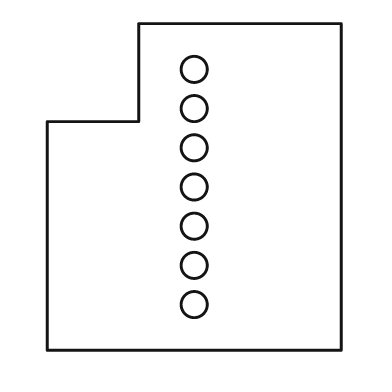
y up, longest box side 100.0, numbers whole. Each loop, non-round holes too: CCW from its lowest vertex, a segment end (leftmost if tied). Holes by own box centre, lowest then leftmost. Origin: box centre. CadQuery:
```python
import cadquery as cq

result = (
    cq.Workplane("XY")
    .moveTo(-45.0, -50.0)
    .lineTo(45.0, -50.0)
    .lineTo(45.0, 50.0)
    .lineTo(-17.0, 50.0)
    .lineTo(-17.0, 20.0)
    .lineTo(-45.0, 20.0)
    .close()
    .moveTo(0.0, -36.0)
    .circle(4.0)
    .moveTo(0.0, -24.0)
    .circle(4.0)
    .moveTo(0.0, -12.0)
    .circle(4.0)
    .moveTo(0.0, 0.0)
    .circle(4.0)
    .moveTo(0.0, 12.0)
    .circle(4.0)
    .moveTo(0.0, 24.0)
    .circle(4.0)
    .moveTo(0.0, 36.0)
    .circle(4.0)
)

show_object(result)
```